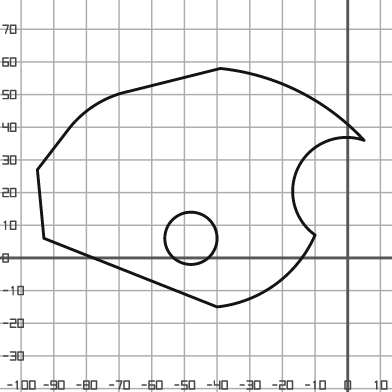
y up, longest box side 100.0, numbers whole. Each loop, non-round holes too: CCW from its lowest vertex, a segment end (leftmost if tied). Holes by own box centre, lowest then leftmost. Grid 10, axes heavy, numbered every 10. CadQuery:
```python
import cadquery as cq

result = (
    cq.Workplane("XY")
    .moveTo(-40.0, -15.0)
    .threePointArc((-22.0, -8.0), (-10.0, 7.0))
    .threePointArc((-15.0, 28.0), (5.0, 36.0))
    .threePointArc((-15.0, 51.0), (-39.0, 58.0))
    .lineTo(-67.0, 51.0)
    .threePointArc((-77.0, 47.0), (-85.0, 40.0))
    .lineTo(-95.0, 27.0)
    .lineTo(-93.0, 6.0)
    .close()
    .moveTo(-48.0, 6.0)
    .circle(8.0)
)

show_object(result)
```